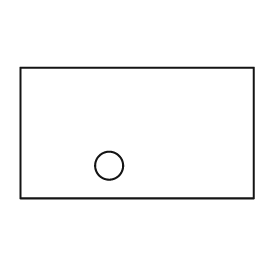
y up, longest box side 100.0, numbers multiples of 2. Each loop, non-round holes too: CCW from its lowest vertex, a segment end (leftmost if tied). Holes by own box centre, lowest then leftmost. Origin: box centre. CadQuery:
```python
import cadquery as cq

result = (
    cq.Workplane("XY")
    .moveTo(-50.0, -28.0)
    .lineTo(50.0, -28.0)
    .lineTo(50.0, 28.0)
    .lineTo(-50.0, 28.0)
    .close()
    .moveTo(-12.0, -14.0)
    .circle(6.0)
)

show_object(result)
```